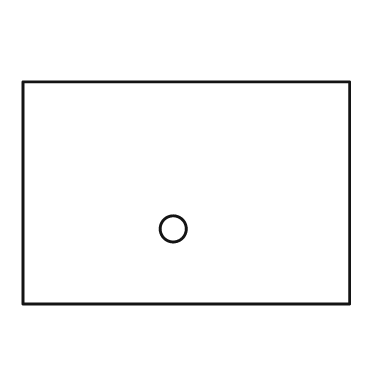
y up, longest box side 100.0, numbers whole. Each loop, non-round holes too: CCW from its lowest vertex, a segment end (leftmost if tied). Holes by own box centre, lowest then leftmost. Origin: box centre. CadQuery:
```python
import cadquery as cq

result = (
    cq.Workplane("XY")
    .moveTo(-50.0, -34.0)
    .lineTo(50.0, -34.0)
    .lineTo(50.0, 34.0)
    .lineTo(-50.0, 34.0)
    .close()
    .moveTo(-4.0, -11.0)
    .circle(4.0)
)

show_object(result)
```